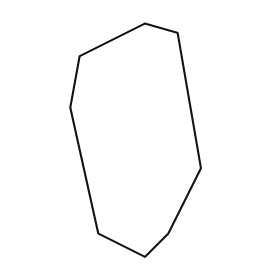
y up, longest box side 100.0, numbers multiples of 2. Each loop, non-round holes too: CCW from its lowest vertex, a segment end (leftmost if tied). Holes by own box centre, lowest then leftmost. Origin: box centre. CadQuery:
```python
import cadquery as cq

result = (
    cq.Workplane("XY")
    .moveTo(4.0, -50.0)
    .lineTo(14.0, -40.0)
    .lineTo(28.0, -12.0)
    .lineTo(18.0, 46.0)
    .lineTo(4.0, 50.0)
    .lineTo(-24.0, 36.0)
    .lineTo(-28.0, 14.0)
    .lineTo(-16.0, -40.0)
    .close()
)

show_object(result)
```